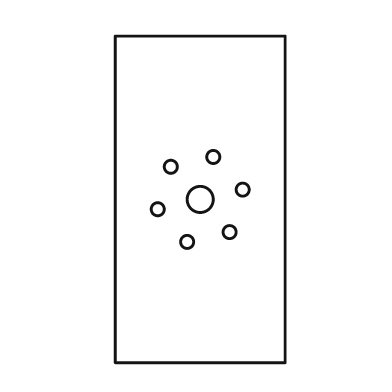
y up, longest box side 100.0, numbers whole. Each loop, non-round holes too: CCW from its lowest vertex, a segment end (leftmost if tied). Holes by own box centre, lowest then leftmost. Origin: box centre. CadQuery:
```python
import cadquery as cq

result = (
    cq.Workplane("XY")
    .moveTo(-26.0, -50.0)
    .lineTo(26.0, -50.0)
    .lineTo(26.0, 50.0)
    .lineTo(-26.0, 50.0)
    .close()
    .moveTo(-4.0, -13.0)
    .circle(2.0)
    .moveTo(9.0, -10.0)
    .circle(2.0)
    .moveTo(-13.0, -3.0)
    .circle(2.0)
    .moveTo(0.0, 0.0)
    .circle(4.0)
    .moveTo(13.0, 3.0)
    .circle(2.0)
    .moveTo(-9.0, 10.0)
    .circle(2.0)
    .moveTo(4.0, 13.0)
    .circle(2.0)
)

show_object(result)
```